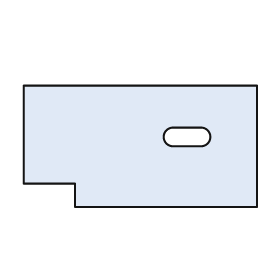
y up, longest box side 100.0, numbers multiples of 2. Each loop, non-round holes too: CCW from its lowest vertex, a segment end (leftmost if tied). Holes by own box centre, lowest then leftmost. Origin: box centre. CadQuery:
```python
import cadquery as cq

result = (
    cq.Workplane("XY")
    .moveTo(-28.0, -26.0)
    .lineTo(50.0, -26.0)
    .lineTo(50.0, 26.0)
    .lineTo(-50.0, 26.0)
    .lineTo(-50.0, -16.0)
    .lineTo(-28.0, -16.0)
    .close()
    .moveTo(14.0, 0.0)
    .lineTo(26.0, 0.0)
    .threePointArc((30.0, 4.0), (26.0, 8.0))
    .lineTo(14.0, 8.0)
    .threePointArc((10.0, 4.0), (14.0, 0.0))
    .close()
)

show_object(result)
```